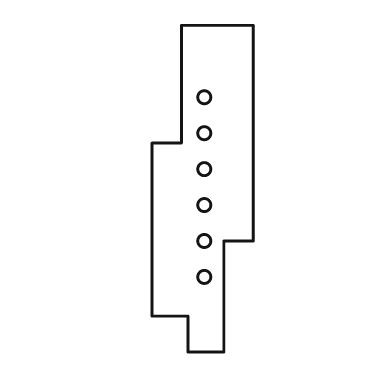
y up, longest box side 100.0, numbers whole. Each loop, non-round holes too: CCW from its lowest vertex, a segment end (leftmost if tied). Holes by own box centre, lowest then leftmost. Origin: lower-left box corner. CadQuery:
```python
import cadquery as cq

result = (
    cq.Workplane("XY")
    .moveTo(11.0, 0.0)
    .lineTo(22.0, 0.0)
    .lineTo(22.0, 34.0)
    .lineTo(31.0, 34.0)
    .lineTo(31.0, 100.0)
    .lineTo(9.0, 100.0)
    .lineTo(9.0, 64.0)
    .lineTo(0.0, 64.0)
    .lineTo(0.0, 11.0)
    .lineTo(11.0, 11.0)
    .close()
    .moveTo(16.0, 23.0)
    .circle(2.0)
    .moveTo(16.0, 34.0)
    .circle(2.0)
    .moveTo(16.0, 45.0)
    .circle(2.0)
    .moveTo(16.0, 56.0)
    .circle(2.0)
    .moveTo(16.0, 67.0)
    .circle(2.0)
    .moveTo(16.0, 78.0)
    .circle(2.0)
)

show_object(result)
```